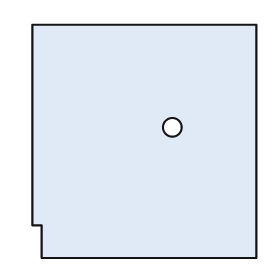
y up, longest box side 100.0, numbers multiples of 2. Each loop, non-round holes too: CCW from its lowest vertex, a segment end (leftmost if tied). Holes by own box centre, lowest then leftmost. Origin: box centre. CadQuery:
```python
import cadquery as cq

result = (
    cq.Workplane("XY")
    .moveTo(-44.0, -50.0)
    .lineTo(48.0, -50.0)
    .lineTo(48.0, 50.0)
    .lineTo(-48.0, 50.0)
    .lineTo(-48.0, -36.0)
    .lineTo(-44.0, -36.0)
    .close()
    .moveTo(12.0, 6.0)
    .circle(4.0)
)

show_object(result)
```